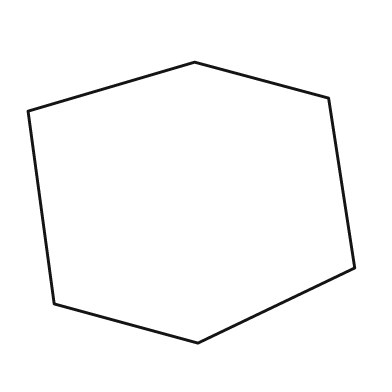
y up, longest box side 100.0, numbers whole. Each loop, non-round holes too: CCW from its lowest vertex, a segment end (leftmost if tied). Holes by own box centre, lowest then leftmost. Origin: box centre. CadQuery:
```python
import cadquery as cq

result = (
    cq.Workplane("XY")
    .moveTo(2.0, -43.0)
    .lineTo(50.0, -20.0)
    .lineTo(42.0, 32.0)
    .lineTo(1.0, 43.0)
    .lineTo(-50.0, 28.0)
    .lineTo(-42.0, -31.0)
    .close()
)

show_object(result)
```